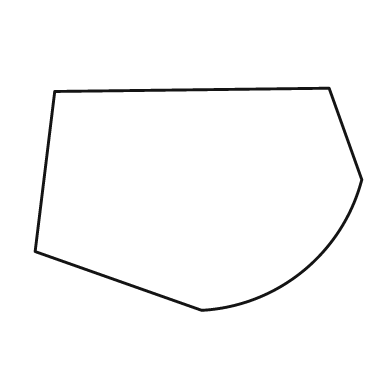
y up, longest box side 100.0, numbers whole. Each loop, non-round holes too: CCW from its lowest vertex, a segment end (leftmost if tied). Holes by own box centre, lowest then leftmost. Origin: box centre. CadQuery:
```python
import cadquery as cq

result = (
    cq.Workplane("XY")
    .moveTo(1.0, -34.0)
    .threePointArc((32.0, -22.0), (50.0, 6.0))
    .lineTo(40.0, 34.0)
    .lineTo(-44.0, 33.0)
    .lineTo(-50.0, -16.0)
    .close()
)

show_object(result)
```